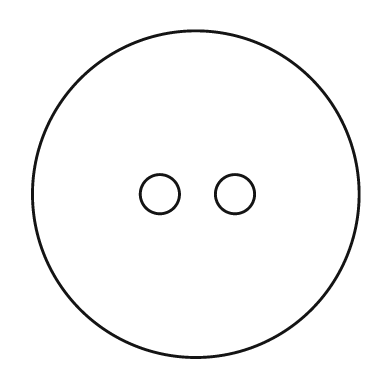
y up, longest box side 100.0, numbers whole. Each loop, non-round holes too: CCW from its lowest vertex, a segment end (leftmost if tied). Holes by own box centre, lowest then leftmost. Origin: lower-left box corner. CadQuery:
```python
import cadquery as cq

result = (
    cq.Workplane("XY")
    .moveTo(50.0, 50.0)
    .circle(50.0)
    .moveTo(39.0, 50.0)
    .circle(6.0)
    .moveTo(62.0, 50.0)
    .circle(6.0)
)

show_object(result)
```